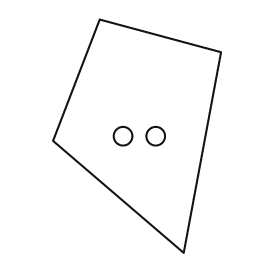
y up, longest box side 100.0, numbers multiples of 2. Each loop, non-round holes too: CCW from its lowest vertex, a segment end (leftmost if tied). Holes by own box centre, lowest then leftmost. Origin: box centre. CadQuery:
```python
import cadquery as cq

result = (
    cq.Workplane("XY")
    .moveTo(20.0, -50.0)
    .lineTo(36.0, 36.0)
    .lineTo(-16.0, 50.0)
    .lineTo(-36.0, -2.0)
    .close()
    .moveTo(-6.0, 0.0)
    .circle(4.0)
    .moveTo(8.0, 0.0)
    .circle(4.0)
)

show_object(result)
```